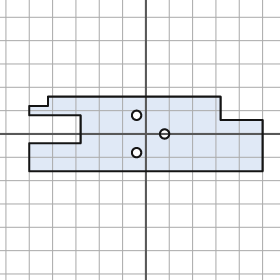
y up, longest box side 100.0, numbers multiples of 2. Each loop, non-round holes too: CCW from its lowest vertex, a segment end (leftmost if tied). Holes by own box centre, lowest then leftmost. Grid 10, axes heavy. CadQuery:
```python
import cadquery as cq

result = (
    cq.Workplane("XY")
    .moveTo(-50.0, -16.0)
    .lineTo(50.0, -16.0)
    .lineTo(50.0, 6.0)
    .lineTo(32.0, 6.0)
    .lineTo(32.0, 16.0)
    .lineTo(-42.0, 16.0)
    .lineTo(-42.0, 12.0)
    .lineTo(-50.0, 12.0)
    .lineTo(-50.0, 8.0)
    .lineTo(-28.0, 8.0)
    .lineTo(-28.0, -4.0)
    .lineTo(-50.0, -4.0)
    .close()
    .moveTo(-4.0, -8.0)
    .circle(2.0)
    .moveTo(8.0, 0.0)
    .circle(2.0)
    .moveTo(-4.0, 8.0)
    .circle(2.0)
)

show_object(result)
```